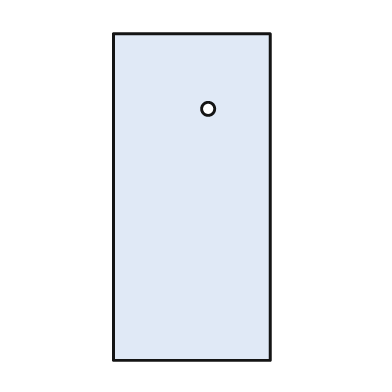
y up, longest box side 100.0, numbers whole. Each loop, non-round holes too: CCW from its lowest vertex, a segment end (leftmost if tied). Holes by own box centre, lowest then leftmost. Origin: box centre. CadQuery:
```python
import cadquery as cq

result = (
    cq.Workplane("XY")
    .moveTo(-24.0, -50.0)
    .lineTo(24.0, -50.0)
    .lineTo(24.0, 50.0)
    .lineTo(-24.0, 50.0)
    .close()
    .moveTo(5.0, 27.0)
    .circle(2.0)
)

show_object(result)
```